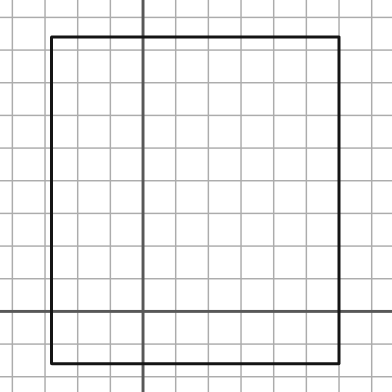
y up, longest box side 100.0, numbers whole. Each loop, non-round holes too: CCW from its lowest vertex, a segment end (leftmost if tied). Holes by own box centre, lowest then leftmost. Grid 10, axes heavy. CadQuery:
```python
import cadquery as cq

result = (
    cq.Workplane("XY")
    .moveTo(-28.0, -16.0)
    .lineTo(60.0, -16.0)
    .lineTo(60.0, 84.0)
    .lineTo(-28.0, 84.0)
    .close()
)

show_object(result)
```